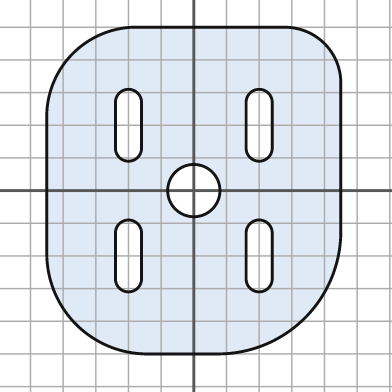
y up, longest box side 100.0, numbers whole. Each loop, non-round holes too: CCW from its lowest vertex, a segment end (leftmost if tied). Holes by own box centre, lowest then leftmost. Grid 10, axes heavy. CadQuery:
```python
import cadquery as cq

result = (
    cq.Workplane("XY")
    .moveTo(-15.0, -50.0)
    .lineTo(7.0, -50.0)
    .threePointArc((34.0, -39.0), (45.0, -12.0))
    .lineTo(45.0, 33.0)
    .threePointArc((40.0, 45.0), (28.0, 50.0))
    .lineTo(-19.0, 50.0)
    .threePointArc((-37.0, 42.0), (-45.0, 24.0))
    .lineTo(-45.0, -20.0)
    .threePointArc((-36.0, -41.0), (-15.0, -50.0))
    .close()
    .moveTo(-24.0, -27.0)
    .threePointArc((-20.0, -31.0), (-16.0, -27.0))
    .lineTo(-16.0, -13.0)
    .threePointArc((-20.0, -9.0), (-24.0, -13.0))
    .close()
    .moveTo(16.0, -27.0)
    .threePointArc((20.0, -31.0), (24.0, -27.0))
    .lineTo(24.0, -13.0)
    .threePointArc((20.0, -9.0), (16.0, -13.0))
    .close()
    .moveTo(0.0, 0.0)
    .circle(8.0)
    .moveTo(-24.0, 13.0)
    .threePointArc((-20.0, 9.0), (-16.0, 13.0))
    .lineTo(-16.0, 27.0)
    .threePointArc((-20.0, 31.0), (-24.0, 27.0))
    .close()
    .moveTo(16.0, 13.0)
    .threePointArc((20.0, 9.0), (24.0, 13.0))
    .lineTo(24.0, 27.0)
    .threePointArc((20.0, 31.0), (16.0, 27.0))
    .close()
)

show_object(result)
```